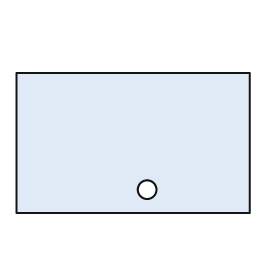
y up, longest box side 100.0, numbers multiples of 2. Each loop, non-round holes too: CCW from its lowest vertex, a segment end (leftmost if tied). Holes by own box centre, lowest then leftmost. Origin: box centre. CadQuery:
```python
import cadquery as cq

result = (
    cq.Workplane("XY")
    .moveTo(-50.0, -30.0)
    .lineTo(50.0, -30.0)
    .lineTo(50.0, 30.0)
    .lineTo(-50.0, 30.0)
    .close()
    .moveTo(6.0, -20.0)
    .circle(4.0)
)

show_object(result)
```